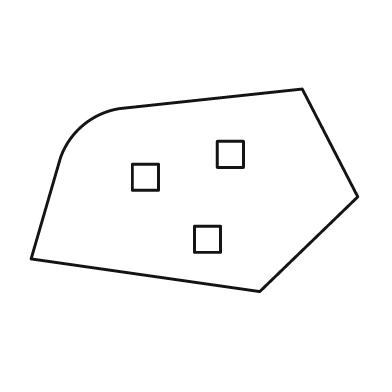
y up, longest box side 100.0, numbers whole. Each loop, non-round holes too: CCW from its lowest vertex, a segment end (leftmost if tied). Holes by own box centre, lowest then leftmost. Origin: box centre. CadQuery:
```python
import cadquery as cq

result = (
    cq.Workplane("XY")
    .moveTo(20.0, -31.0)
    .lineTo(50.0, -2.0)
    .lineTo(33.0, 31.0)
    .lineTo(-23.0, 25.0)
    .threePointArc((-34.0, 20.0), (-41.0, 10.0))
    .lineTo(-50.0, -21.0)
    .close()
    .moveTo(0.0, -19.0)
    .lineTo(8.0, -19.0)
    .lineTo(8.0, -11.0)
    .lineTo(0.0, -11.0)
    .close()
    .moveTo(-19.0, 0.0)
    .lineTo(-11.0, 0.0)
    .lineTo(-11.0, 8.0)
    .lineTo(-19.0, 8.0)
    .close()
    .moveTo(7.0, 7.0)
    .lineTo(15.0, 7.0)
    .lineTo(15.0, 15.0)
    .lineTo(7.0, 15.0)
    .close()
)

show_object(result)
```